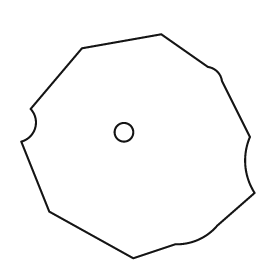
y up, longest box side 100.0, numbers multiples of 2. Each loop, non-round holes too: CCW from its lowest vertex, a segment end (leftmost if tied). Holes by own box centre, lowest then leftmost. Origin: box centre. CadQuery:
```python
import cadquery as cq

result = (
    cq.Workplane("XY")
    .moveTo(-2.0, -48.0)
    .lineTo(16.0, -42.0)
    .threePointArc((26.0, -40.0), (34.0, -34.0))
    .lineTo(50.0, -20.0)
    .threePointArc((46.0, -8.0), (48.0, 4.0))
    .lineTo(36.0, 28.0)
    .threePointArc((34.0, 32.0), (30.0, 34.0))
    .lineTo(10.0, 48.0)
    .lineTo(-24.0, 42.0)
    .lineTo(-46.0, 16.0)
    .threePointArc((-44.0, 8.0), (-50.0, 2.0))
    .lineTo(-38.0, -28.0)
    .close()
    .moveTo(-6.0, 6.0)
    .circle(4.0)
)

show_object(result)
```